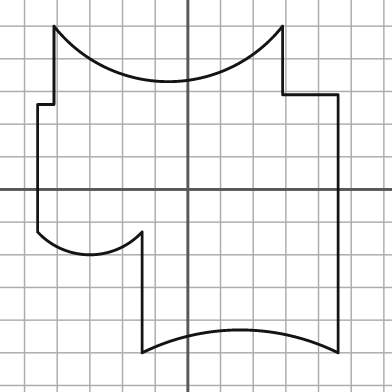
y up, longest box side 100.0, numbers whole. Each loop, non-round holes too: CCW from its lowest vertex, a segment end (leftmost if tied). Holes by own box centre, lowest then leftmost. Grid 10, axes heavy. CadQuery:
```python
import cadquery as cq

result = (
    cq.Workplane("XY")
    .moveTo(-14.0, -50.0)
    .threePointArc((16.0, -43.0), (46.0, -50.0))
    .lineTo(46.0, 29.0)
    .lineTo(29.0, 29.0)
    .lineTo(29.0, 50.0)
    .threePointArc((-6.0, 33.0), (-41.0, 50.0))
    .lineTo(-41.0, 26.0)
    .lineTo(-46.0, 26.0)
    .lineTo(-46.0, -13.0)
    .threePointArc((-30.0, -20.0), (-14.0, -13.0))
    .close()
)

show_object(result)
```